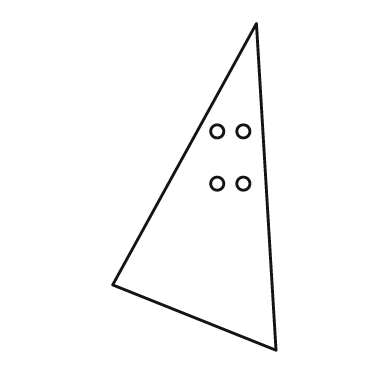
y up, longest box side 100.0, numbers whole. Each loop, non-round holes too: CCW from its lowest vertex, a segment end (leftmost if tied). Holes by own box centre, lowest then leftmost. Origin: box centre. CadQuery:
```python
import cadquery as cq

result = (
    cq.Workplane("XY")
    .moveTo(25.0, -50.0)
    .lineTo(19.0, 50.0)
    .lineTo(-25.0, -30.0)
    .close()
    .moveTo(7.0, 1.0)
    .circle(2.0)
    .moveTo(15.0, 1.0)
    .circle(2.0)
    .moveTo(7.0, 17.0)
    .circle(2.0)
    .moveTo(15.0, 17.0)
    .circle(2.0)
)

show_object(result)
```